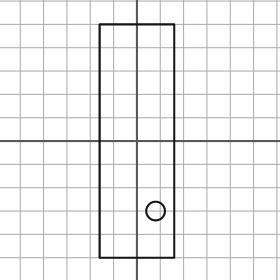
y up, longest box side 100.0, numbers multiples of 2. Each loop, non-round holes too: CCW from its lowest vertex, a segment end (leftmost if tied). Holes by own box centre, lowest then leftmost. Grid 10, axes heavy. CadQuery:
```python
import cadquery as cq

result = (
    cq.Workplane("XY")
    .moveTo(-16.0, -50.0)
    .lineTo(16.0, -50.0)
    .lineTo(16.0, 50.0)
    .lineTo(-16.0, 50.0)
    .close()
    .moveTo(8.0, -30.0)
    .circle(4.0)
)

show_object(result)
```